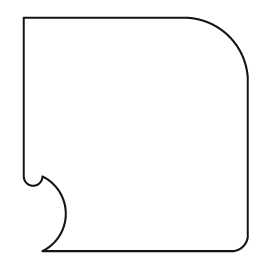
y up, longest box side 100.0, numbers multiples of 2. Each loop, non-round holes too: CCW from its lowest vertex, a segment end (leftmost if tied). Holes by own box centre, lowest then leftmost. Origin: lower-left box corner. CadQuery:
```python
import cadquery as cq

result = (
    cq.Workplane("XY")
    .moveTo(8.0, 0.0)
    .lineTo(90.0, 0.0)
    .threePointArc((94.0, 2.0), (96.0, 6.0))
    .lineTo(96.0, 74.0)
    .threePointArc((88.0, 92.0), (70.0, 100.0))
    .lineTo(0.0, 100.0)
    .lineTo(0.0, 32.0)
    .threePointArc((4.0, 28.0), (8.0, 32.0))
    .threePointArc((18.0, 16.0), (8.0, 0.0))
    .close()
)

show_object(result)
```